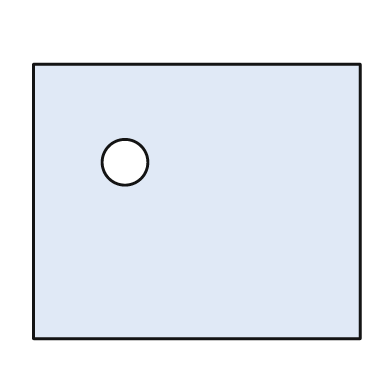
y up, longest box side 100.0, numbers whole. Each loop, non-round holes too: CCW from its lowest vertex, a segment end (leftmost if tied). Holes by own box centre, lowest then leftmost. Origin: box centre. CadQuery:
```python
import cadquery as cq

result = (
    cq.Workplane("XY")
    .moveTo(-50.0, -42.0)
    .lineTo(50.0, -42.0)
    .lineTo(50.0, 42.0)
    .lineTo(-50.0, 42.0)
    .close()
    .moveTo(-22.0, 12.0)
    .circle(7.0)
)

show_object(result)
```